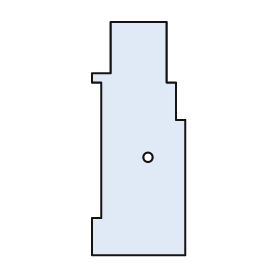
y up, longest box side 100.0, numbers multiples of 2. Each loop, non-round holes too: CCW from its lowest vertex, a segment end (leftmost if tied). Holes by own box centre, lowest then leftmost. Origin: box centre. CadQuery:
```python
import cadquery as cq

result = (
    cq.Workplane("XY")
    .moveTo(-20.0, -50.0)
    .lineTo(20.0, -50.0)
    .lineTo(20.0, 8.0)
    .lineTo(16.0, 8.0)
    .lineTo(16.0, 24.0)
    .lineTo(12.0, 24.0)
    .lineTo(12.0, 50.0)
    .lineTo(-12.0, 50.0)
    .lineTo(-12.0, 28.0)
    .lineTo(-20.0, 28.0)
    .lineTo(-20.0, 24.0)
    .lineTo(-16.0, 24.0)
    .lineTo(-16.0, -34.0)
    .lineTo(-20.0, -34.0)
    .close()
    .moveTo(4.0, -8.0)
    .circle(2.0)
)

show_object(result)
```